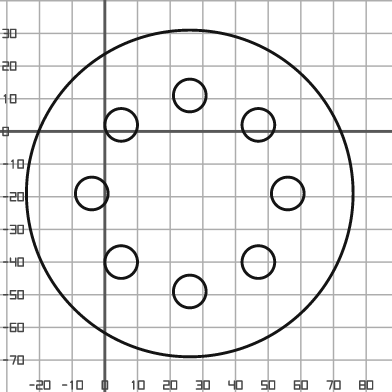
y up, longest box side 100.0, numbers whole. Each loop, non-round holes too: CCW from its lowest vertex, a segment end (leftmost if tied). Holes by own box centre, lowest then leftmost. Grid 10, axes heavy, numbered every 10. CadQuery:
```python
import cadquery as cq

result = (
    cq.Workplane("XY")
    .moveTo(26.0, -19.0)
    .circle(50.0)
    .moveTo(26.0, -49.0)
    .circle(5.0)
    .moveTo(5.0, -40.0)
    .circle(5.0)
    .moveTo(47.0, -40.0)
    .circle(5.0)
    .moveTo(-4.0, -19.0)
    .circle(5.0)
    .moveTo(56.0, -19.0)
    .circle(5.0)
    .moveTo(5.0, 2.0)
    .circle(5.0)
    .moveTo(47.0, 2.0)
    .circle(5.0)
    .moveTo(26.0, 11.0)
    .circle(5.0)
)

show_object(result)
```